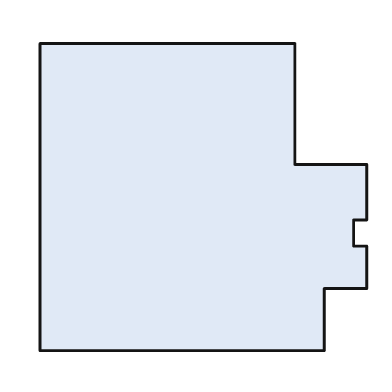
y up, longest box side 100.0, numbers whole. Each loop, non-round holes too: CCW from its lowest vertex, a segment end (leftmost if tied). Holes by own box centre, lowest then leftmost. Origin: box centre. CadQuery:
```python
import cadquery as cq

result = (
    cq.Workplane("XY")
    .moveTo(-50.0, -47.0)
    .lineTo(37.0, -47.0)
    .lineTo(37.0, -28.0)
    .lineTo(50.0, -28.0)
    .lineTo(50.0, -15.0)
    .lineTo(46.0, -15.0)
    .lineTo(46.0, -7.0)
    .lineTo(50.0, -7.0)
    .lineTo(50.0, 10.0)
    .lineTo(28.0, 10.0)
    .lineTo(28.0, 47.0)
    .lineTo(-50.0, 47.0)
    .close()
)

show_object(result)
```